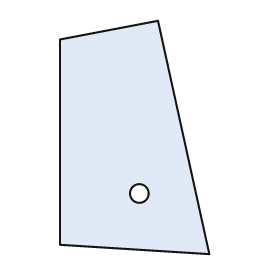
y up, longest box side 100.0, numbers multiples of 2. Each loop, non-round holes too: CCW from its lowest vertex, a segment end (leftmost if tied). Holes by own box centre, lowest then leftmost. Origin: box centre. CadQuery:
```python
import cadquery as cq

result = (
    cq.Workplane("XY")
    .moveTo(32.0, -50.0)
    .lineTo(10.0, 50.0)
    .lineTo(-32.0, 42.0)
    .lineTo(-32.0, -46.0)
    .close()
    .moveTo(2.0, -24.0)
    .circle(4.0)
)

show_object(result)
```